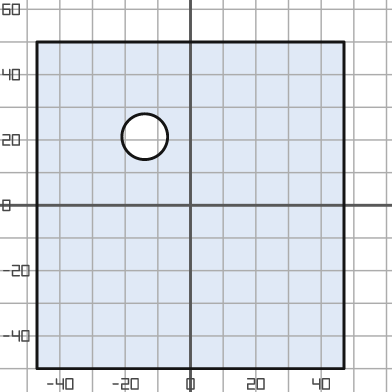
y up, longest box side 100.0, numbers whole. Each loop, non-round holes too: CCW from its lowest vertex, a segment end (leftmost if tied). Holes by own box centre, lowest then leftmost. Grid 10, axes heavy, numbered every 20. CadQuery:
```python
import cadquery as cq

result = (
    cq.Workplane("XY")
    .moveTo(-47.0, -50.0)
    .lineTo(47.0, -50.0)
    .lineTo(47.0, 50.0)
    .lineTo(-47.0, 50.0)
    .close()
    .moveTo(-14.0, 21.0)
    .circle(7.0)
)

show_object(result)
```